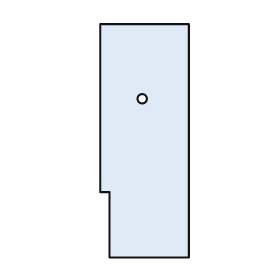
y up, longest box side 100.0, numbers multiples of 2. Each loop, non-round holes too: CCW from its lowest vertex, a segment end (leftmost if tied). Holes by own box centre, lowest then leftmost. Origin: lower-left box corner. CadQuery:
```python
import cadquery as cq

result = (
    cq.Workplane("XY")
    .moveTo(4.0, 0.0)
    .lineTo(38.0, 0.0)
    .lineTo(38.0, 100.0)
    .lineTo(0.0, 100.0)
    .lineTo(0.0, 28.0)
    .lineTo(4.0, 28.0)
    .close()
    .moveTo(18.0, 68.0)
    .circle(2.0)
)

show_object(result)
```